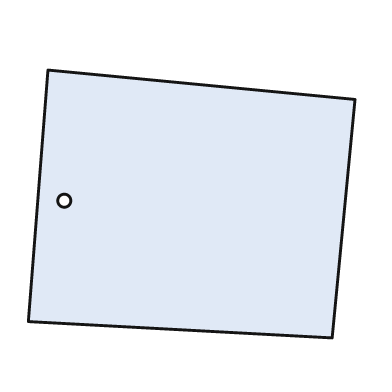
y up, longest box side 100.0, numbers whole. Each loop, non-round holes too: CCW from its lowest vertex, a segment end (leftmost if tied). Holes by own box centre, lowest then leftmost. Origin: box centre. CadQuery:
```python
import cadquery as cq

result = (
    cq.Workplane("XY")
    .moveTo(43.0, -41.0)
    .lineTo(50.0, 32.0)
    .lineTo(-44.0, 41.0)
    .lineTo(-50.0, -36.0)
    .close()
    .moveTo(-39.0, 1.0)
    .circle(2.0)
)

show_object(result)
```